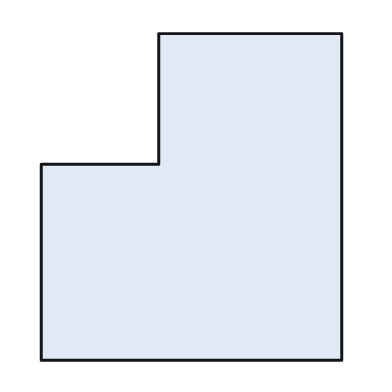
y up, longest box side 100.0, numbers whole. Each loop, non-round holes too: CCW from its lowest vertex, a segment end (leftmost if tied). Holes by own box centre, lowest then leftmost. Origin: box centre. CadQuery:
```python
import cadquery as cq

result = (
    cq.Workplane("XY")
    .moveTo(-46.0, -50.0)
    .lineTo(46.0, -50.0)
    .lineTo(46.0, 50.0)
    .lineTo(-10.0, 50.0)
    .lineTo(-10.0, 10.0)
    .lineTo(-46.0, 10.0)
    .close()
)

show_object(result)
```